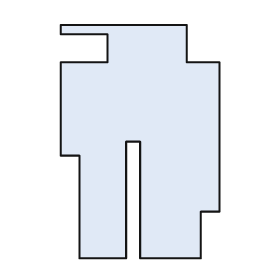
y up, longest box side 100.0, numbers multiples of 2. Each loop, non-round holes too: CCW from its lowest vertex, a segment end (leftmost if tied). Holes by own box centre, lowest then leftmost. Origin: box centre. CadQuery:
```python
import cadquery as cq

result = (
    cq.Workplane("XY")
    .moveTo(-26.0, -50.0)
    .lineTo(-6.0, -50.0)
    .lineTo(-6.0, 0.0)
    .lineTo(0.0, 0.0)
    .lineTo(0.0, -50.0)
    .lineTo(26.0, -50.0)
    .lineTo(26.0, -30.0)
    .lineTo(34.0, -30.0)
    .lineTo(34.0, 34.0)
    .lineTo(20.0, 34.0)
    .lineTo(20.0, 50.0)
    .lineTo(-34.0, 50.0)
    .lineTo(-34.0, 46.0)
    .lineTo(-14.0, 46.0)
    .lineTo(-14.0, 34.0)
    .lineTo(-34.0, 34.0)
    .lineTo(-34.0, -6.0)
    .lineTo(-26.0, -6.0)
    .close()
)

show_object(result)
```